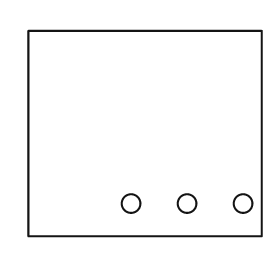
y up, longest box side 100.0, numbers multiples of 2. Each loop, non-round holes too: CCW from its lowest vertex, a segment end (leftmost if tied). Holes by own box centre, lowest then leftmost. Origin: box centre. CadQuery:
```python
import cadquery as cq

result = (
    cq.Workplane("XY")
    .moveTo(-50.0, -44.0)
    .lineTo(50.0, -44.0)
    .lineTo(50.0, 44.0)
    .lineTo(-50.0, 44.0)
    .close()
    .moveTo(-6.0, -30.0)
    .circle(4.0)
    .moveTo(18.0, -30.0)
    .circle(4.0)
    .moveTo(42.0, -30.0)
    .circle(4.0)
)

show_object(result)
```